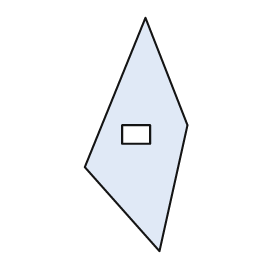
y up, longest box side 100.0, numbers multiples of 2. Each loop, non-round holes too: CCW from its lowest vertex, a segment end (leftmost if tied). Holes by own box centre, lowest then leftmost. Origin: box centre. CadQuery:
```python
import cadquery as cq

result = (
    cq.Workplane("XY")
    .moveTo(10.0, -50.0)
    .lineTo(22.0, 4.0)
    .lineTo(4.0, 50.0)
    .lineTo(-22.0, -14.0)
    .close()
    .moveTo(-6.0, -4.0)
    .lineTo(6.0, -4.0)
    .lineTo(6.0, 4.0)
    .lineTo(-6.0, 4.0)
    .close()
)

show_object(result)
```